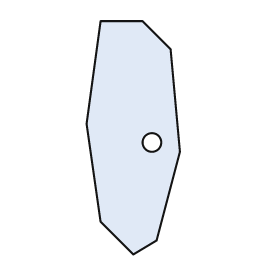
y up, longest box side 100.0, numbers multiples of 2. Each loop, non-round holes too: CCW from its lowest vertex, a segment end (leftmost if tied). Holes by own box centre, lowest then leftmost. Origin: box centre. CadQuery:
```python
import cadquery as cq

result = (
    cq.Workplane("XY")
    .moveTo(0.0, -50.0)
    .lineTo(10.0, -44.0)
    .lineTo(20.0, -6.0)
    .lineTo(16.0, 38.0)
    .lineTo(4.0, 50.0)
    .lineTo(-14.0, 50.0)
    .lineTo(-20.0, 6.0)
    .lineTo(-14.0, -36.0)
    .close()
    .moveTo(8.0, -2.0)
    .circle(4.0)
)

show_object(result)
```